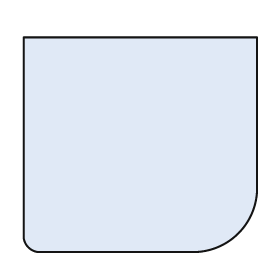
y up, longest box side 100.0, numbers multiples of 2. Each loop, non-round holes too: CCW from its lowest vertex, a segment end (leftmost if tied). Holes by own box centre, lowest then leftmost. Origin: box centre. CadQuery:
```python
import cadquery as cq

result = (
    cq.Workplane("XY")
    .moveTo(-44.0, -46.0)
    .lineTo(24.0, -46.0)
    .threePointArc((42.0, -38.0), (50.0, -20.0))
    .lineTo(50.0, 46.0)
    .lineTo(-50.0, 46.0)
    .lineTo(-50.0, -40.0)
    .threePointArc((-48.0, -44.0), (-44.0, -46.0))
    .close()
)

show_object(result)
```